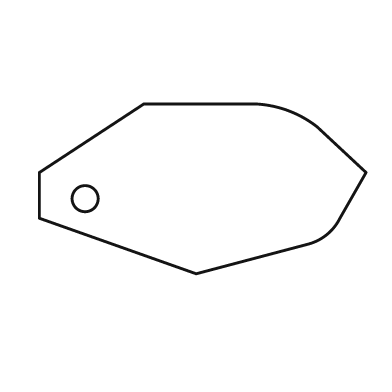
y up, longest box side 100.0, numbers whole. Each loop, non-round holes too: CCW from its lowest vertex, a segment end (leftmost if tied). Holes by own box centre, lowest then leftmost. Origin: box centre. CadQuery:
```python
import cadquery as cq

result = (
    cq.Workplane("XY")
    .moveTo(-2.0, -26.0)
    .lineTo(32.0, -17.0)
    .threePointArc((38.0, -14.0), (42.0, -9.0))
    .lineTo(50.0, 5.0)
    .lineTo(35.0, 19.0)
    .threePointArc((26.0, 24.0), (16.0, 26.0))
    .lineTo(-18.0, 26.0)
    .lineTo(-50.0, 5.0)
    .lineTo(-50.0, -9.0)
    .close()
    .moveTo(-36.0, -3.0)
    .circle(4.0)
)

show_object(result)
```